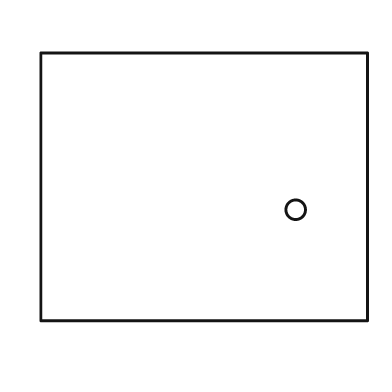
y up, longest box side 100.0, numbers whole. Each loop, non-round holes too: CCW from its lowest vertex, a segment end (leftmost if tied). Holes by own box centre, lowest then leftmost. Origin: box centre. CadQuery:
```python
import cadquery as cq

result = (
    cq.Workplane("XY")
    .moveTo(-50.0, -41.0)
    .lineTo(50.0, -41.0)
    .lineTo(50.0, 41.0)
    .lineTo(-50.0, 41.0)
    .close()
    .moveTo(28.0, -7.0)
    .circle(3.0)
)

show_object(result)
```